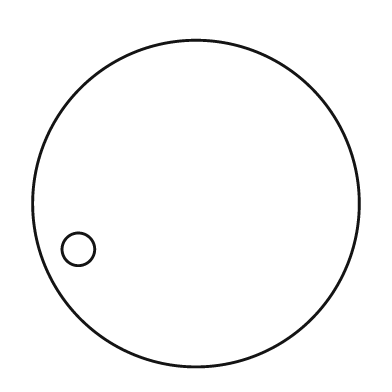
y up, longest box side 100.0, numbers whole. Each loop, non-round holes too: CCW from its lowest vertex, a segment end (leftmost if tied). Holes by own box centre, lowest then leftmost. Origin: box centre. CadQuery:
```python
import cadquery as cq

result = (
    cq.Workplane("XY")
    .moveTo(0.0, 0.0)
    .circle(50.0)
    .moveTo(-36.0, -14.0)
    .circle(5.0)
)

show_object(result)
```